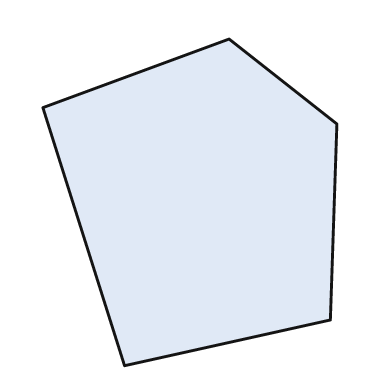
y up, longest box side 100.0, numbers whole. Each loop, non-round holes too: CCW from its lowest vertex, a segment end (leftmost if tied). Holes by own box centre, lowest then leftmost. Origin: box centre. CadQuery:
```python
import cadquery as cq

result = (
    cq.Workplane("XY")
    .moveTo(-20.0, -50.0)
    .lineTo(43.0, -36.0)
    .lineTo(45.0, 24.0)
    .lineTo(12.0, 50.0)
    .lineTo(-45.0, 29.0)
    .close()
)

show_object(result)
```